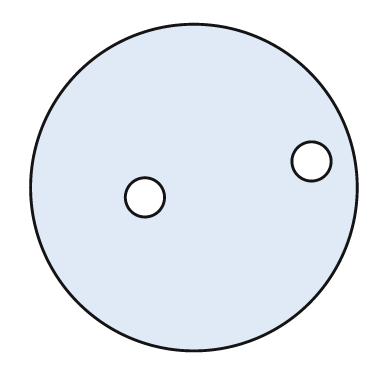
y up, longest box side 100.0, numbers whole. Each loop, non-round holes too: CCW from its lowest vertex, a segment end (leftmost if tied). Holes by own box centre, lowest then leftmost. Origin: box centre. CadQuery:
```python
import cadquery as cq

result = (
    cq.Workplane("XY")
    .moveTo(0.0, 0.0)
    .circle(50.0)
    .moveTo(-15.0, -3.0)
    .circle(6.0)
    .moveTo(36.0, 8.0)
    .circle(6.0)
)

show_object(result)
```